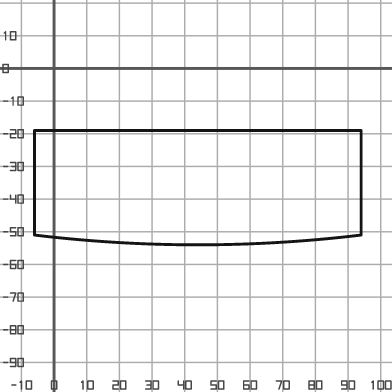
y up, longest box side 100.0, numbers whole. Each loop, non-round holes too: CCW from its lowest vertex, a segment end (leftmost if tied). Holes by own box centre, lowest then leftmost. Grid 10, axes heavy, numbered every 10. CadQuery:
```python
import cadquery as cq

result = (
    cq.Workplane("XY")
    .moveTo(-6.0, -51.0)
    .threePointArc((44.0, -54.0), (94.0, -51.0))
    .lineTo(94.0, -19.0)
    .lineTo(-6.0, -19.0)
    .close()
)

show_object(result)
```